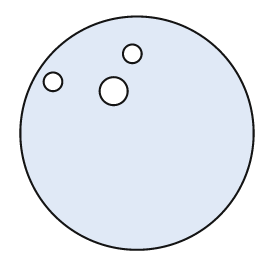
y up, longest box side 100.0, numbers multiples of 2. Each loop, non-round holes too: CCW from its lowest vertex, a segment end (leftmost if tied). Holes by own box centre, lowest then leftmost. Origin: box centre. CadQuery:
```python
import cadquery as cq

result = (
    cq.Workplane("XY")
    .moveTo(0.0, 0.0)
    .circle(50.0)
    .moveTo(-10.0, 18.0)
    .circle(6.0)
    .moveTo(-36.0, 22.0)
    .circle(4.0)
    .moveTo(-2.0, 34.0)
    .circle(4.0)
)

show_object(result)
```